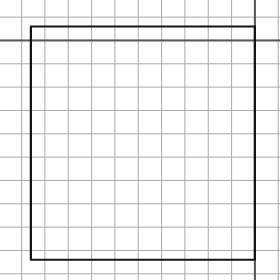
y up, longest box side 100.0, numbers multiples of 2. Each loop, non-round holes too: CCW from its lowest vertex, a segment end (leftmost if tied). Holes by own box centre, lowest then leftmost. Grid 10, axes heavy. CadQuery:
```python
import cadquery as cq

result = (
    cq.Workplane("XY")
    .moveTo(-96.0, -94.0)
    .lineTo(0.0, -94.0)
    .lineTo(0.0, 6.0)
    .lineTo(-96.0, 6.0)
    .close()
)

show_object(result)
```